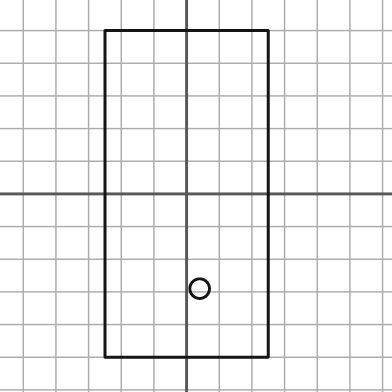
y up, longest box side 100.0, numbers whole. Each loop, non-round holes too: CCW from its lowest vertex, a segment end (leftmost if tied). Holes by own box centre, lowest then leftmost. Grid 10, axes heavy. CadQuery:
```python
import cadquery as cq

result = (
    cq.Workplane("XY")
    .moveTo(-25.0, -50.0)
    .lineTo(25.0, -50.0)
    .lineTo(25.0, 50.0)
    .lineTo(-25.0, 50.0)
    .close()
    .moveTo(4.0, -29.0)
    .circle(3.0)
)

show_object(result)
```